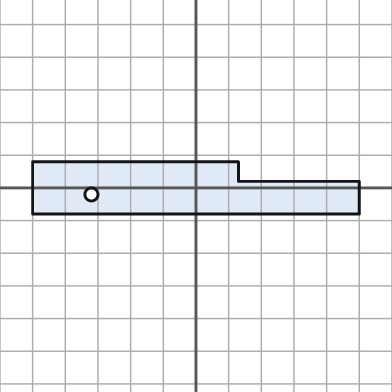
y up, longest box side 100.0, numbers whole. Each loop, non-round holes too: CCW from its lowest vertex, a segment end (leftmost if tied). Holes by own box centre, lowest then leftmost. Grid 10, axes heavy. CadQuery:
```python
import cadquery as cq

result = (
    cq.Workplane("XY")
    .moveTo(-50.0, -8.0)
    .lineTo(50.0, -8.0)
    .lineTo(50.0, 2.0)
    .lineTo(13.0, 2.0)
    .lineTo(13.0, 8.0)
    .lineTo(-50.0, 8.0)
    .close()
    .moveTo(-32.0, -2.0)
    .circle(2.0)
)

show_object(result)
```